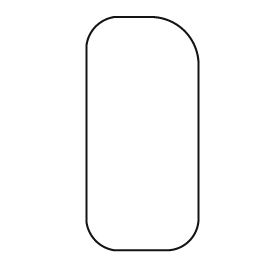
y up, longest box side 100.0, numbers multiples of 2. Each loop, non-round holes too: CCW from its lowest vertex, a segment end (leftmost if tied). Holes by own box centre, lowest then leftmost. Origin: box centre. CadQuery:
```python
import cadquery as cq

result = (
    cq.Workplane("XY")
    .moveTo(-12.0, -50.0)
    .lineTo(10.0, -50.0)
    .threePointArc((20.0, -46.0), (24.0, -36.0))
    .lineTo(24.0, 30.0)
    .threePointArc((18.0, 44.0), (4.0, 50.0))
    .lineTo(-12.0, 50.0)
    .threePointArc((-20.0, 46.0), (-24.0, 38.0))
    .lineTo(-24.0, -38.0)
    .threePointArc((-20.0, -46.0), (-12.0, -50.0))
    .close()
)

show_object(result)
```